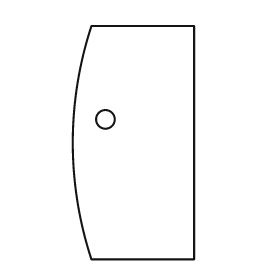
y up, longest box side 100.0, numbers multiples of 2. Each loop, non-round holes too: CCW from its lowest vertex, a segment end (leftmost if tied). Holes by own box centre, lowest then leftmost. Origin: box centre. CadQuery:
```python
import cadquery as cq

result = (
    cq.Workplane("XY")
    .moveTo(-18.0, -50.0)
    .lineTo(26.0, -50.0)
    .lineTo(26.0, 50.0)
    .lineTo(-18.0, 50.0)
    .threePointArc((-26.0, 0.0), (-18.0, -50.0))
    .close()
    .moveTo(-12.0, 10.0)
    .circle(4.0)
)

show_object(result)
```